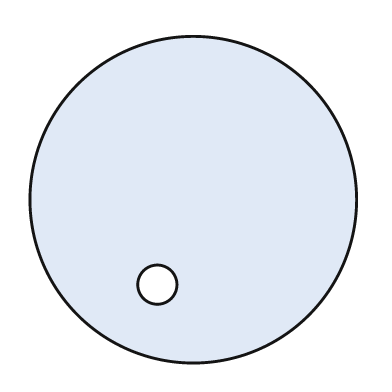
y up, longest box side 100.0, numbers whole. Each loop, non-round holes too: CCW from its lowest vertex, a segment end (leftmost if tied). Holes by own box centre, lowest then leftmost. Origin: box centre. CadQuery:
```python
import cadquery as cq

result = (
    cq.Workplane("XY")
    .moveTo(0.0, 0.0)
    .circle(50.0)
    .moveTo(-11.0, -26.0)
    .circle(6.0)
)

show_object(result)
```